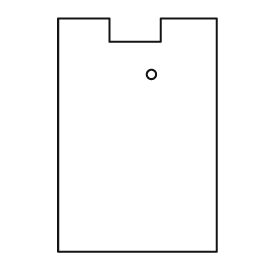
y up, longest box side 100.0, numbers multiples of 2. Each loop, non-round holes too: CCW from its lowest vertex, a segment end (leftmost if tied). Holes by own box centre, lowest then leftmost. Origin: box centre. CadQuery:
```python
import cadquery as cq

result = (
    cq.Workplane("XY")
    .moveTo(-34.0, -50.0)
    .lineTo(34.0, -50.0)
    .lineTo(34.0, 50.0)
    .lineTo(10.0, 50.0)
    .lineTo(10.0, 40.0)
    .lineTo(-12.0, 40.0)
    .lineTo(-12.0, 50.0)
    .lineTo(-34.0, 50.0)
    .close()
    .moveTo(6.0, 26.0)
    .circle(2.0)
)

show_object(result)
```